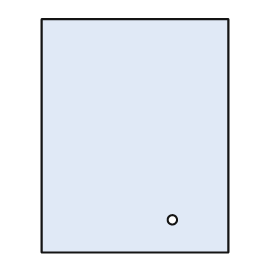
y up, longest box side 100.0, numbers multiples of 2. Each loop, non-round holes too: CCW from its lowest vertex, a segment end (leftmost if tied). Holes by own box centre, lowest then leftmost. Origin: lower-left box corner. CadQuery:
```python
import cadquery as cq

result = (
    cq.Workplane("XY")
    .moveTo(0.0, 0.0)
    .lineTo(80.0, 0.0)
    .lineTo(80.0, 100.0)
    .lineTo(0.0, 100.0)
    .close()
    .moveTo(56.0, 14.0)
    .circle(2.0)
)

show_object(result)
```